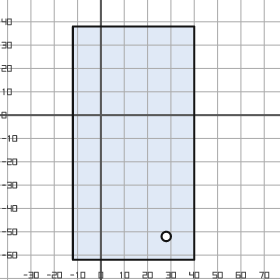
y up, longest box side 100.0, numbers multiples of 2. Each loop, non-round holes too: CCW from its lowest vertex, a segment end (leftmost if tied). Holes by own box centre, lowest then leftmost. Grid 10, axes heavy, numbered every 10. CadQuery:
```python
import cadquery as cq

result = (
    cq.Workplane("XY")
    .moveTo(-12.0, -62.0)
    .lineTo(40.0, -62.0)
    .lineTo(40.0, 38.0)
    .lineTo(-12.0, 38.0)
    .close()
    .moveTo(28.0, -52.0)
    .circle(2.0)
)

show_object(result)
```